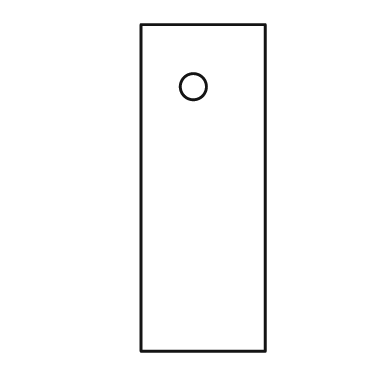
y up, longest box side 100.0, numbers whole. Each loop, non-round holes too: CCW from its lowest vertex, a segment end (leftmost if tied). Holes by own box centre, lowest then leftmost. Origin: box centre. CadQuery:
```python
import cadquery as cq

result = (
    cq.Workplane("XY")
    .moveTo(-19.0, -50.0)
    .lineTo(19.0, -50.0)
    .lineTo(19.0, 50.0)
    .lineTo(-19.0, 50.0)
    .close()
    .moveTo(-3.0, 31.0)
    .circle(4.0)
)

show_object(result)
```